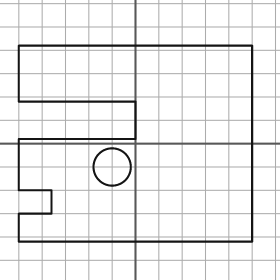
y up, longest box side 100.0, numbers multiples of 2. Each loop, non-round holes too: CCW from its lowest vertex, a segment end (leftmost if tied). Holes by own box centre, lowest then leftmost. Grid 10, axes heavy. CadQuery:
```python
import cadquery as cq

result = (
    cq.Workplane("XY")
    .moveTo(-50.0, -42.0)
    .lineTo(50.0, -42.0)
    .lineTo(50.0, 42.0)
    .lineTo(-50.0, 42.0)
    .lineTo(-50.0, 18.0)
    .lineTo(0.0, 18.0)
    .lineTo(0.0, 2.0)
    .lineTo(-50.0, 2.0)
    .lineTo(-50.0, -20.0)
    .lineTo(-36.0, -20.0)
    .lineTo(-36.0, -30.0)
    .lineTo(-50.0, -30.0)
    .close()
    .moveTo(-10.0, -10.0)
    .circle(8.0)
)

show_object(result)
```